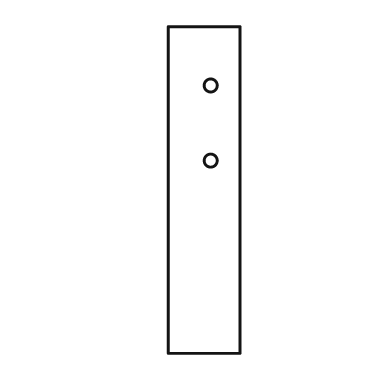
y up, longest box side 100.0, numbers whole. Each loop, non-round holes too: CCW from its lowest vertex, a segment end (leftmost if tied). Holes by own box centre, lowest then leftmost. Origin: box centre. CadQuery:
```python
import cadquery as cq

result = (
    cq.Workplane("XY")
    .moveTo(-11.0, -50.0)
    .lineTo(11.0, -50.0)
    .lineTo(11.0, 50.0)
    .lineTo(-11.0, 50.0)
    .close()
    .moveTo(2.0, 9.0)
    .circle(2.0)
    .moveTo(2.0, 32.0)
    .circle(2.0)
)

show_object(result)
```